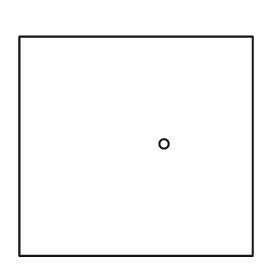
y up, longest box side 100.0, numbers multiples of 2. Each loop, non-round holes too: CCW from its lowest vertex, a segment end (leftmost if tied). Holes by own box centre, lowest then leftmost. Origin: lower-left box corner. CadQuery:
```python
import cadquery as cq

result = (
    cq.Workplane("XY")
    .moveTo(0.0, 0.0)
    .lineTo(100.0, 0.0)
    .lineTo(100.0, 94.0)
    .lineTo(0.0, 94.0)
    .close()
    .moveTo(62.0, 48.0)
    .circle(2.0)
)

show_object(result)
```